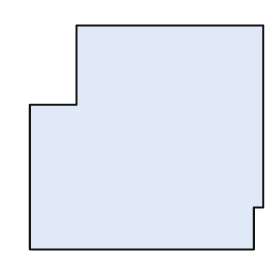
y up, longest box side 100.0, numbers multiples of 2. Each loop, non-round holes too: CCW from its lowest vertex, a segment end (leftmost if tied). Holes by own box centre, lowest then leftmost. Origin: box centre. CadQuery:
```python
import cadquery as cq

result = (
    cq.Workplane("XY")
    .moveTo(-50.0, -48.0)
    .lineTo(46.0, -48.0)
    .lineTo(46.0, -30.0)
    .lineTo(50.0, -30.0)
    .lineTo(50.0, 48.0)
    .lineTo(-30.0, 48.0)
    .lineTo(-30.0, 14.0)
    .lineTo(-50.0, 14.0)
    .close()
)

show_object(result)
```